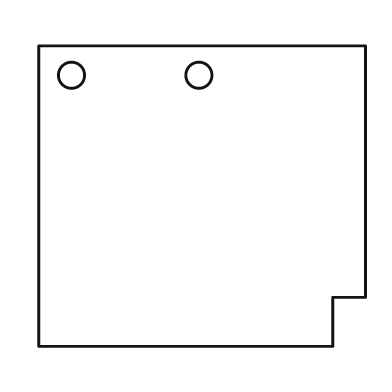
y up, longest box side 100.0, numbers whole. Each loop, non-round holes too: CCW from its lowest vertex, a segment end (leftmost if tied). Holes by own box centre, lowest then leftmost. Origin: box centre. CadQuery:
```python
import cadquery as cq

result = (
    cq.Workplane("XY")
    .moveTo(-50.0, -46.0)
    .lineTo(40.0, -46.0)
    .lineTo(40.0, -31.0)
    .lineTo(50.0, -31.0)
    .lineTo(50.0, 46.0)
    .lineTo(-50.0, 46.0)
    .close()
    .moveTo(-40.0, 37.0)
    .circle(4.0)
    .moveTo(-1.0, 37.0)
    .circle(4.0)
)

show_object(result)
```